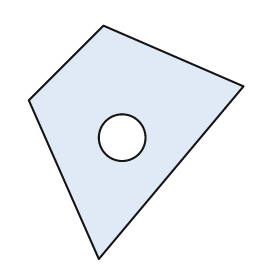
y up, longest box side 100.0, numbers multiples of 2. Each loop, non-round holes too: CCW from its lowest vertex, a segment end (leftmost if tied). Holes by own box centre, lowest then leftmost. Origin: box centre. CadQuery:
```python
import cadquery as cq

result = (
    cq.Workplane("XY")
    .moveTo(-16.0, -50.0)
    .lineTo(46.0, 24.0)
    .lineTo(-14.0, 50.0)
    .lineTo(-46.0, 18.0)
    .close()
    .moveTo(-6.0, 2.0)
    .circle(10.0)
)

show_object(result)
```